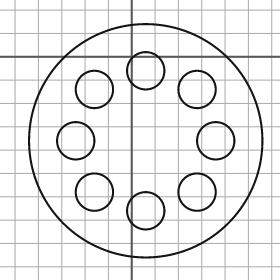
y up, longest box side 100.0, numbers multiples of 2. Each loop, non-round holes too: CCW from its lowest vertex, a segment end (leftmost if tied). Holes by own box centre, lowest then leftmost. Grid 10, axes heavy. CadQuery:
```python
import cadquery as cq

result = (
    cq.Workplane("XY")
    .moveTo(6.0, -36.0)
    .circle(50.0)
    .moveTo(6.0, -66.0)
    .circle(8.0)
    .moveTo(-16.0, -58.0)
    .circle(8.0)
    .moveTo(28.0, -58.0)
    .circle(8.0)
    .moveTo(-24.0, -36.0)
    .circle(8.0)
    .moveTo(36.0, -36.0)
    .circle(8.0)
    .moveTo(-16.0, -14.0)
    .circle(8.0)
    .moveTo(28.0, -14.0)
    .circle(8.0)
    .moveTo(6.0, -6.0)
    .circle(8.0)
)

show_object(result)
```